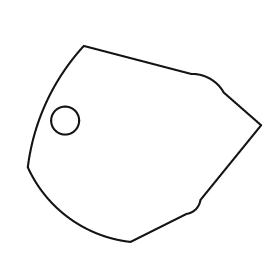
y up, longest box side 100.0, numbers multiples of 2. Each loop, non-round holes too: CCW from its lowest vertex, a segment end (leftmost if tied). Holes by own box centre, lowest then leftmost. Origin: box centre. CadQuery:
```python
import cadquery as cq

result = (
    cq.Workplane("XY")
    .moveTo(-6.0, -42.0)
    .lineTo(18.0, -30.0)
    .threePointArc((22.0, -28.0), (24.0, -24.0))
    .lineTo(50.0, 8.0)
    .lineTo(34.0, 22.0)
    .threePointArc((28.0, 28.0), (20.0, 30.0))
    .lineTo(-26.0, 42.0)
    .threePointArc((-42.0, 18.0), (-50.0, -10.0))
    .threePointArc((-32.0, -32.0), (-6.0, -42.0))
    .close()
    .moveTo(-34.0, 10.0)
    .circle(6.0)
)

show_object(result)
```